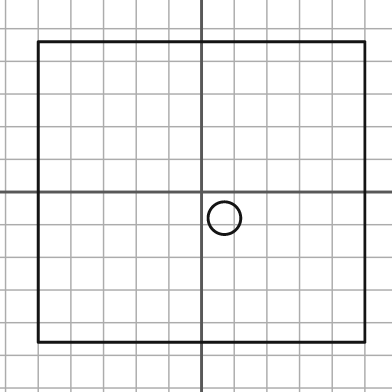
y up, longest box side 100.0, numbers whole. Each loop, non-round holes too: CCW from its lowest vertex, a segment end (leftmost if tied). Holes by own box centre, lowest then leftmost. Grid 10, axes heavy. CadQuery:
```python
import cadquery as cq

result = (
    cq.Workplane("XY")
    .moveTo(-50.0, -46.0)
    .lineTo(50.0, -46.0)
    .lineTo(50.0, 46.0)
    .lineTo(-50.0, 46.0)
    .close()
    .moveTo(7.0, -8.0)
    .circle(5.0)
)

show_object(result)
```